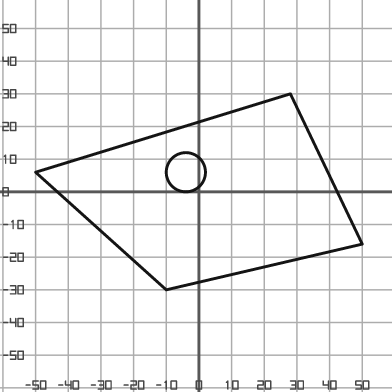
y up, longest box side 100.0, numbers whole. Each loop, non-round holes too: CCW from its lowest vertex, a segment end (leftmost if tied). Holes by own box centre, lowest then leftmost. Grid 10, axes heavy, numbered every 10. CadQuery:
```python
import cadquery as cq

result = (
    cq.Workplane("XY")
    .moveTo(-10.0, -30.0)
    .lineTo(50.0, -16.0)
    .lineTo(28.0, 30.0)
    .lineTo(-50.0, 6.0)
    .close()
    .moveTo(-4.0, 6.0)
    .circle(6.0)
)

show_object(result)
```